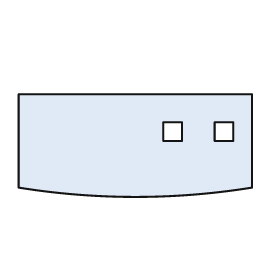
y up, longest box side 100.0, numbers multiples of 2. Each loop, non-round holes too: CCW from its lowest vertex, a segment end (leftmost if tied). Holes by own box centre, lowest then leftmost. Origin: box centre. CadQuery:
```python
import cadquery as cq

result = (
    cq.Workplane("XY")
    .moveTo(-50.0, -18.0)
    .threePointArc((0.0, -22.0), (50.0, -18.0))
    .lineTo(50.0, 22.0)
    .lineTo(-50.0, 22.0)
    .close()
    .moveTo(12.0, 2.0)
    .lineTo(20.0, 2.0)
    .lineTo(20.0, 10.0)
    .lineTo(12.0, 10.0)
    .close()
    .moveTo(34.0, 2.0)
    .lineTo(42.0, 2.0)
    .lineTo(42.0, 10.0)
    .lineTo(34.0, 10.0)
    .close()
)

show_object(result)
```